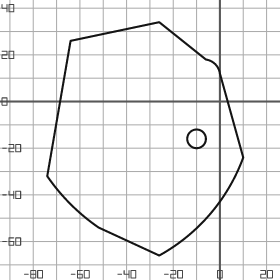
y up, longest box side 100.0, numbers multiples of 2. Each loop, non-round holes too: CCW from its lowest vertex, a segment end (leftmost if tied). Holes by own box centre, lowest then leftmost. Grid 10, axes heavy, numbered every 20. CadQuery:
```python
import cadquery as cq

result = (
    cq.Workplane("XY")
    .moveTo(-26.0, -66.0)
    .threePointArc((-4.0, -48.0), (10.0, -24.0))
    .lineTo(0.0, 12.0)
    .threePointArc((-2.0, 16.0), (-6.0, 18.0))
    .lineTo(-26.0, 34.0)
    .lineTo(-64.0, 26.0)
    .lineTo(-74.0, -32.0)
    .threePointArc((-64.0, -44.0), (-52.0, -54.0))
    .close()
    .moveTo(-10.0, -16.0)
    .circle(4.0)
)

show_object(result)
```